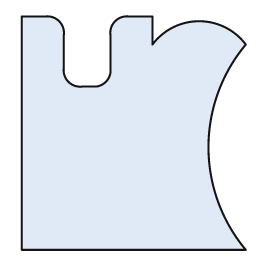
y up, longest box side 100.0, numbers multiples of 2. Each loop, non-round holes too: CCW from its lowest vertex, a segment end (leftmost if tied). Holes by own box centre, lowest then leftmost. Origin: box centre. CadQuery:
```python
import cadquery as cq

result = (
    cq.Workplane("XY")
    .moveTo(-48.0, -50.0)
    .lineTo(48.0, -50.0)
    .threePointArc((32.0, -6.0), (48.0, 38.0))
    .threePointArc((28.0, 48.0), (8.0, 38.0))
    .lineTo(8.0, 50.0)
    .lineTo(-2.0, 50.0)
    .threePointArc((-8.0, 48.0), (-10.0, 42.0))
    .lineTo(-10.0, 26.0)
    .threePointArc((-12.0, 22.0), (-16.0, 20.0))
    .lineTo(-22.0, 20.0)
    .threePointArc((-28.0, 22.0), (-30.0, 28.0))
    .lineTo(-30.0, 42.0)
    .threePointArc((-32.0, 48.0), (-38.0, 50.0))
    .lineTo(-48.0, 50.0)
    .close()
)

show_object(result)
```